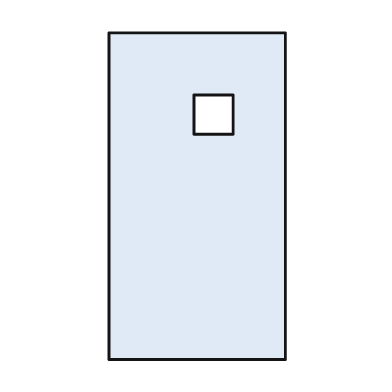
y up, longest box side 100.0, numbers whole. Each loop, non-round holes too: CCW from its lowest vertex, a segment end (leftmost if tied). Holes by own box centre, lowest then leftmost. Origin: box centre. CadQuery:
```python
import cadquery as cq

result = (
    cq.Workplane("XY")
    .moveTo(-27.0, -50.0)
    .lineTo(27.0, -50.0)
    .lineTo(27.0, 50.0)
    .lineTo(-27.0, 50.0)
    .close()
    .moveTo(-1.0, 19.0)
    .lineTo(11.0, 19.0)
    .lineTo(11.0, 31.0)
    .lineTo(-1.0, 31.0)
    .close()
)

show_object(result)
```